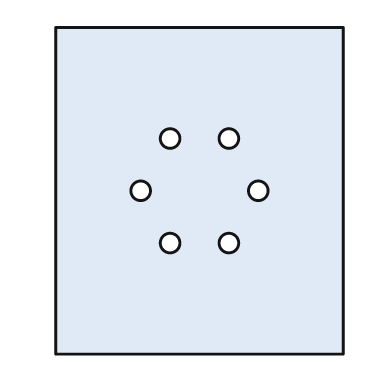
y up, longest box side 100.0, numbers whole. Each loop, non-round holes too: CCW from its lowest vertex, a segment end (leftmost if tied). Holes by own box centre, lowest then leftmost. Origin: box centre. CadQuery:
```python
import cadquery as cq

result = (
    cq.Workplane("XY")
    .moveTo(-44.0, -50.0)
    .lineTo(44.0, -50.0)
    .lineTo(44.0, 50.0)
    .lineTo(-44.0, 50.0)
    .close()
    .moveTo(-9.0, -16.0)
    .circle(3.0)
    .moveTo(9.0, -16.0)
    .circle(3.0)
    .moveTo(-18.0, 0.0)
    .circle(3.0)
    .moveTo(18.0, 0.0)
    .circle(3.0)
    .moveTo(-9.0, 16.0)
    .circle(3.0)
    .moveTo(9.0, 16.0)
    .circle(3.0)
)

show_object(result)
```